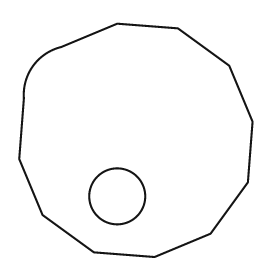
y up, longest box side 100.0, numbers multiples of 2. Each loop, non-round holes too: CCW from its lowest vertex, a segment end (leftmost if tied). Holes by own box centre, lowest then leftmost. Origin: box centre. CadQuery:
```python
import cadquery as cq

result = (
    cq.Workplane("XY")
    .moveTo(8.0, -50.0)
    .lineTo(32.0, -40.0)
    .lineTo(48.0, -18.0)
    .lineTo(50.0, 8.0)
    .lineTo(40.0, 32.0)
    .lineTo(18.0, 48.0)
    .lineTo(-8.0, 50.0)
    .lineTo(-32.0, 40.0)
    .threePointArc((-44.0, 32.0), (-48.0, 18.0))
    .lineTo(-50.0, -8.0)
    .lineTo(-40.0, -32.0)
    .lineTo(-18.0, -48.0)
    .close()
    .moveTo(-8.0, -24.0)
    .circle(12.0)
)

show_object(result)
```